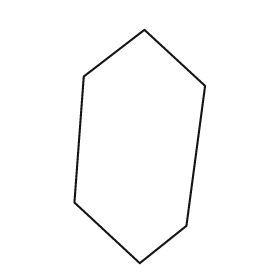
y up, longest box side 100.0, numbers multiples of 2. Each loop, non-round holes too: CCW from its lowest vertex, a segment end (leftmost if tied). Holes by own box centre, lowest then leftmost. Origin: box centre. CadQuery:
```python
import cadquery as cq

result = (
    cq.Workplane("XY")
    .moveTo(0.0, -50.0)
    .lineTo(20.0, -34.0)
    .lineTo(28.0, 26.0)
    .lineTo(2.0, 50.0)
    .lineTo(-24.0, 30.0)
    .lineTo(-28.0, -24.0)
    .close()
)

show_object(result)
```